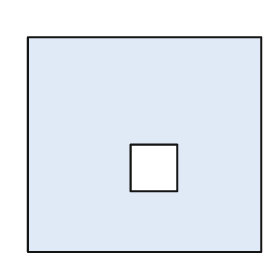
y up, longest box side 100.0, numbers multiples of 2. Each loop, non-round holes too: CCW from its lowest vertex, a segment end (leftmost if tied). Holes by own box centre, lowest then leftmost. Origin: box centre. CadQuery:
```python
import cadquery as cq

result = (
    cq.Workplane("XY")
    .moveTo(-50.0, -46.0)
    .lineTo(50.0, -46.0)
    .lineTo(50.0, 46.0)
    .lineTo(-50.0, 46.0)
    .close()
    .moveTo(-6.0, -20.0)
    .lineTo(14.0, -20.0)
    .lineTo(14.0, 0.0)
    .lineTo(-6.0, 0.0)
    .close()
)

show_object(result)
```